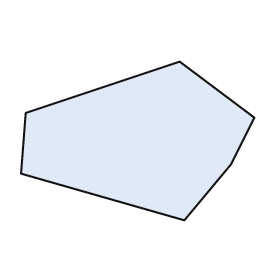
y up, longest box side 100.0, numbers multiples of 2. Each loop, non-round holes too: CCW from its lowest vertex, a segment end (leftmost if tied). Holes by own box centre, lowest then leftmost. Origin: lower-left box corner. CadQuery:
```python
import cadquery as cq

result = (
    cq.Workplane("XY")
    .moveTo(70.0, 0.0)
    .lineTo(90.0, 24.0)
    .lineTo(100.0, 44.0)
    .lineTo(68.0, 68.0)
    .lineTo(2.0, 46.0)
    .lineTo(0.0, 20.0)
    .close()
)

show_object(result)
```